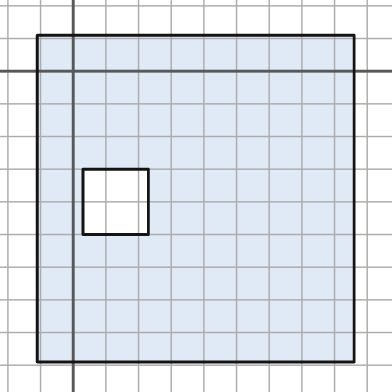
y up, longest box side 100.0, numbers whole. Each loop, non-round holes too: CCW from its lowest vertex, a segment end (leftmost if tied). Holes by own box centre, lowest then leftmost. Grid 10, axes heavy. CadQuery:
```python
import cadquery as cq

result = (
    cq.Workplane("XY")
    .moveTo(-11.0, -89.0)
    .lineTo(86.0, -89.0)
    .lineTo(86.0, 11.0)
    .lineTo(-11.0, 11.0)
    .close()
    .moveTo(3.0, -50.0)
    .lineTo(23.0, -50.0)
    .lineTo(23.0, -30.0)
    .lineTo(3.0, -30.0)
    .close()
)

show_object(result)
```